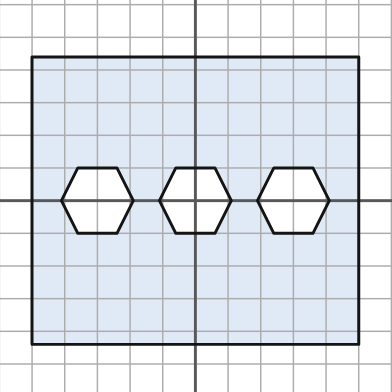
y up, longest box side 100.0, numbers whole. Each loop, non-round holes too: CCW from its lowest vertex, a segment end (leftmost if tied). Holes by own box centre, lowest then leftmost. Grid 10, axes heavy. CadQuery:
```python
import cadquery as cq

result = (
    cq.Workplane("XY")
    .moveTo(-50.0, -44.0)
    .lineTo(50.0, -44.0)
    .lineTo(50.0, 44.0)
    .lineTo(-50.0, 44.0)
    .close()
    .moveTo(-36.0, -10.0)
    .lineTo(-24.0, -10.0)
    .lineTo(-19.0, 0.0)
    .lineTo(-24.0, 10.0)
    .lineTo(-36.0, 10.0)
    .lineTo(-41.0, 0.0)
    .close()
    .moveTo(-6.0, -10.0)
    .lineTo(6.0, -10.0)
    .lineTo(11.0, 0.0)
    .lineTo(6.0, 10.0)
    .lineTo(-6.0, 10.0)
    .lineTo(-11.0, 0.0)
    .close()
    .moveTo(24.0, -10.0)
    .lineTo(36.0, -10.0)
    .lineTo(41.0, 0.0)
    .lineTo(36.0, 10.0)
    .lineTo(24.0, 10.0)
    .lineTo(19.0, 0.0)
    .close()
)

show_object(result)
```